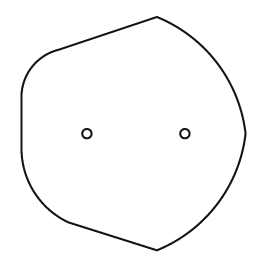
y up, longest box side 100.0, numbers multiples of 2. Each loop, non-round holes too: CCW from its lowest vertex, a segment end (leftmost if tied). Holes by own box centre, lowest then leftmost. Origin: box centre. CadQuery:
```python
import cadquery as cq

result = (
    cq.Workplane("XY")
    .moveTo(10.0, -50.0)
    .threePointArc((36.0, -30.0), (48.0, 0.0))
    .threePointArc((36.0, 30.0), (10.0, 50.0))
    .lineTo(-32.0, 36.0)
    .threePointArc((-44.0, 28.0), (-48.0, 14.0))
    .lineTo(-48.0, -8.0)
    .threePointArc((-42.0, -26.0), (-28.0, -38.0))
    .close()
    .moveTo(-20.0, 0.0)
    .circle(2.0)
    .moveTo(22.0, 0.0)
    .circle(2.0)
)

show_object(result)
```